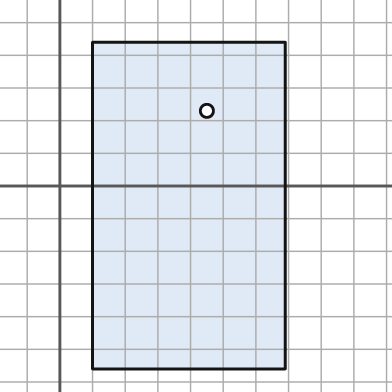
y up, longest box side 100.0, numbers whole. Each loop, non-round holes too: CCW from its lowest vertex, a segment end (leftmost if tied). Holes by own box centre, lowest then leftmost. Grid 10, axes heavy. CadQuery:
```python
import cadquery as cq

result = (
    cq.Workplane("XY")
    .moveTo(10.0, -56.0)
    .lineTo(69.0, -56.0)
    .lineTo(69.0, 44.0)
    .lineTo(10.0, 44.0)
    .close()
    .moveTo(45.0, 23.0)
    .circle(2.0)
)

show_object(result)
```